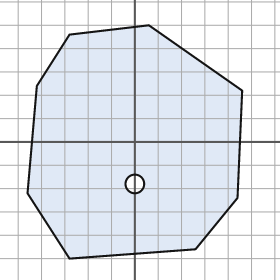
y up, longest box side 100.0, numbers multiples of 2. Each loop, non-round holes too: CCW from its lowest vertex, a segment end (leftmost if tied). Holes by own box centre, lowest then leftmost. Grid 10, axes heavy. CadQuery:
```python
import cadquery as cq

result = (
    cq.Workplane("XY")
    .moveTo(-28.0, -50.0)
    .lineTo(26.0, -46.0)
    .lineTo(44.0, -24.0)
    .lineTo(46.0, 22.0)
    .lineTo(6.0, 50.0)
    .lineTo(-28.0, 46.0)
    .lineTo(-42.0, 24.0)
    .lineTo(-46.0, -22.0)
    .close()
    .moveTo(0.0, -18.0)
    .circle(4.0)
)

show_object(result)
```